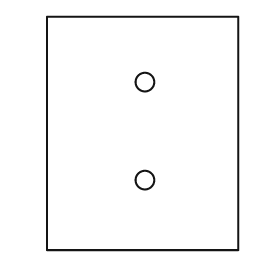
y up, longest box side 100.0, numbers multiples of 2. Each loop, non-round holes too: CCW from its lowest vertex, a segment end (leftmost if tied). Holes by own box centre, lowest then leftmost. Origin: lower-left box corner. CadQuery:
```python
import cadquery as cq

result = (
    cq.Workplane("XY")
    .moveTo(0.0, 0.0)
    .lineTo(82.0, 0.0)
    .lineTo(82.0, 100.0)
    .lineTo(0.0, 100.0)
    .close()
    .moveTo(42.0, 30.0)
    .circle(4.0)
    .moveTo(42.0, 72.0)
    .circle(4.0)
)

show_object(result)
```